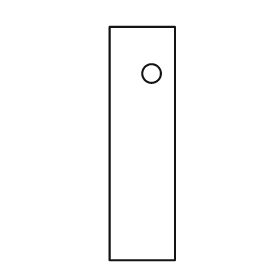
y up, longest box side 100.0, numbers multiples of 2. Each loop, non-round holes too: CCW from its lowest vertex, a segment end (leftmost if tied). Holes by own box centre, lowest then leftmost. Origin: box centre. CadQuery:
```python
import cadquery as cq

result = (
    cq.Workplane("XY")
    .moveTo(-14.0, -50.0)
    .lineTo(14.0, -50.0)
    .lineTo(14.0, 50.0)
    .lineTo(-14.0, 50.0)
    .close()
    .moveTo(4.0, 30.0)
    .circle(4.0)
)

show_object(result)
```